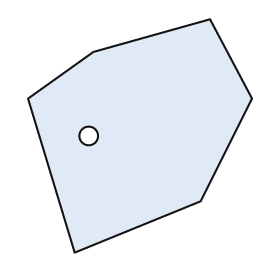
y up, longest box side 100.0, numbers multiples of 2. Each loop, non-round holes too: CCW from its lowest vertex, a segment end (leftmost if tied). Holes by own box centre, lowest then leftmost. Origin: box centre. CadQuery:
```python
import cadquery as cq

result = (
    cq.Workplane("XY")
    .moveTo(-28.0, -50.0)
    .lineTo(26.0, -28.0)
    .lineTo(48.0, 16.0)
    .lineTo(30.0, 50.0)
    .lineTo(-20.0, 36.0)
    .lineTo(-48.0, 16.0)
    .close()
    .moveTo(-22.0, 0.0)
    .circle(4.0)
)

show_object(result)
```